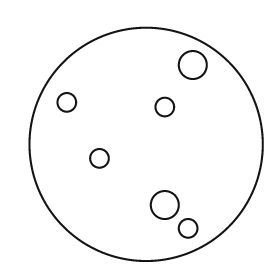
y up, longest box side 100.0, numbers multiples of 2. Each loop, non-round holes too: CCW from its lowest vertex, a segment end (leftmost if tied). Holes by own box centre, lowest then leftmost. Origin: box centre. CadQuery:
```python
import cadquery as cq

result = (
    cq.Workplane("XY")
    .moveTo(0.0, 0.0)
    .circle(50.0)
    .moveTo(18.0, -36.0)
    .circle(4.0)
    .moveTo(8.0, -26.0)
    .circle(6.0)
    .moveTo(-20.0, -6.0)
    .circle(4.0)
    .moveTo(8.0, 16.0)
    .circle(4.0)
    .moveTo(-34.0, 18.0)
    .circle(4.0)
    .moveTo(20.0, 34.0)
    .circle(6.0)
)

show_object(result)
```